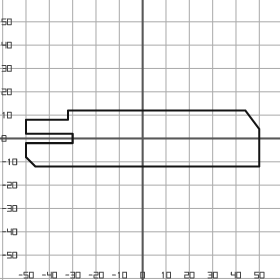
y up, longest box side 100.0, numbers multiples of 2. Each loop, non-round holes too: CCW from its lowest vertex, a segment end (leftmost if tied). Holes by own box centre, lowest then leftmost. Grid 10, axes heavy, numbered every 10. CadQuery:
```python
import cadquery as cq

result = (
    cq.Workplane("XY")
    .moveTo(-46.0, -12.0)
    .lineTo(50.0, -12.0)
    .lineTo(50.0, 4.0)
    .lineTo(44.0, 12.0)
    .lineTo(-32.0, 12.0)
    .lineTo(-32.0, 8.0)
    .lineTo(-50.0, 8.0)
    .lineTo(-50.0, 2.0)
    .lineTo(-30.0, 2.0)
    .lineTo(-30.0, -2.0)
    .lineTo(-50.0, -2.0)
    .lineTo(-50.0, -8.0)
    .close()
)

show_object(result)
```